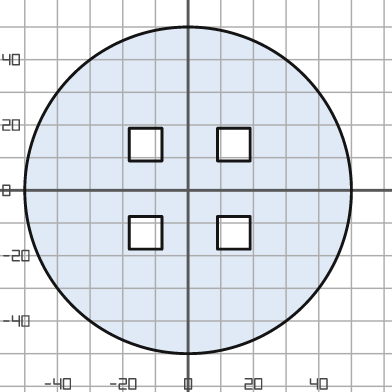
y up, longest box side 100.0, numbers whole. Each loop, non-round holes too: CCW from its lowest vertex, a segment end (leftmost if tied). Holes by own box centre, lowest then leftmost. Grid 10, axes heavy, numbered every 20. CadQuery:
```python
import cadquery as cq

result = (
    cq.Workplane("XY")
    .moveTo(0.0, 0.0)
    .circle(50.0)
    .moveTo(-18.0, -18.0)
    .lineTo(-8.0, -18.0)
    .lineTo(-8.0, -8.0)
    .lineTo(-18.0, -8.0)
    .close()
    .moveTo(9.0, -18.0)
    .lineTo(19.0, -18.0)
    .lineTo(19.0, -8.0)
    .lineTo(9.0, -8.0)
    .close()
    .moveTo(-18.0, 9.0)
    .lineTo(-8.0, 9.0)
    .lineTo(-8.0, 19.0)
    .lineTo(-18.0, 19.0)
    .close()
    .moveTo(9.0, 9.0)
    .lineTo(19.0, 9.0)
    .lineTo(19.0, 19.0)
    .lineTo(9.0, 19.0)
    .close()
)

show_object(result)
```